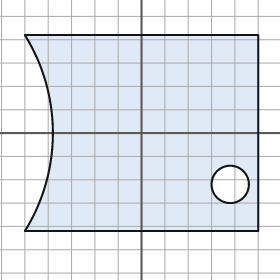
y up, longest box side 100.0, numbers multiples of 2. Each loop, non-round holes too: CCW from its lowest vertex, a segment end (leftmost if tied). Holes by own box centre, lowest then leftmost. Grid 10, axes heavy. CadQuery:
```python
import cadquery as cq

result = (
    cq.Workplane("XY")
    .moveTo(-50.0, -42.0)
    .lineTo(50.0, -42.0)
    .lineTo(50.0, 42.0)
    .lineTo(-50.0, 42.0)
    .threePointArc((-38.0, 0.0), (-50.0, -42.0))
    .close()
    .moveTo(38.0, -22.0)
    .circle(8.0)
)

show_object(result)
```